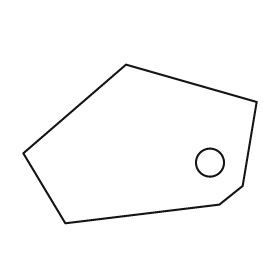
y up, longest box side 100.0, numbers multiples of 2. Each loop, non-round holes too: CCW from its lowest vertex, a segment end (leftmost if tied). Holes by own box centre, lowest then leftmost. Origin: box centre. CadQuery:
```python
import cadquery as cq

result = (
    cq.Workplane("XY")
    .moveTo(-32.0, -34.0)
    .lineTo(34.0, -26.0)
    .lineTo(44.0, -18.0)
    .lineTo(50.0, 18.0)
    .lineTo(-6.0, 34.0)
    .lineTo(-50.0, -4.0)
    .close()
    .moveTo(30.0, -8.0)
    .circle(6.0)
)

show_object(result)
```